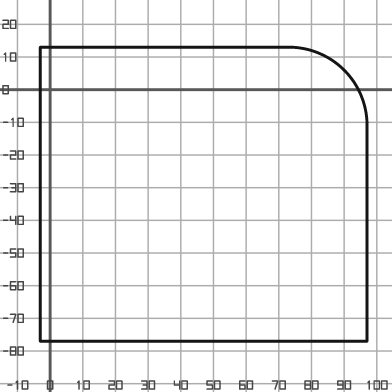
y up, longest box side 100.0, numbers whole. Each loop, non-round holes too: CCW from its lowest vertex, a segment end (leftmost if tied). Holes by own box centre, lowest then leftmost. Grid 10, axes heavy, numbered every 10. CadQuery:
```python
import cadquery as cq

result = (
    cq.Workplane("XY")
    .moveTo(-3.0, -77.0)
    .lineTo(97.0, -77.0)
    .lineTo(97.0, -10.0)
    .threePointArc((90.0, 6.0), (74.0, 13.0))
    .lineTo(-3.0, 13.0)
    .close()
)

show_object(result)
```